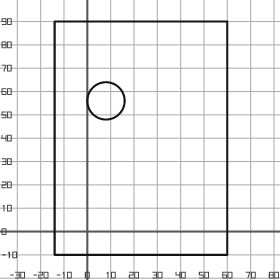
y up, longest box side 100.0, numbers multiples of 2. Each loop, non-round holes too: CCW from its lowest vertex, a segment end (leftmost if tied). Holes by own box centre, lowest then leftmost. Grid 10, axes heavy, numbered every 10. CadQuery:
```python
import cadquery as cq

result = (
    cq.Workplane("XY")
    .moveTo(-14.0, -10.0)
    .lineTo(60.0, -10.0)
    .lineTo(60.0, 90.0)
    .lineTo(-14.0, 90.0)
    .close()
    .moveTo(8.0, 56.0)
    .circle(8.0)
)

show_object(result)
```